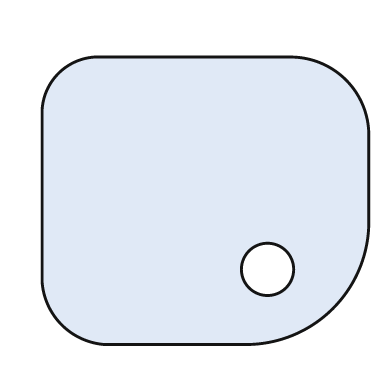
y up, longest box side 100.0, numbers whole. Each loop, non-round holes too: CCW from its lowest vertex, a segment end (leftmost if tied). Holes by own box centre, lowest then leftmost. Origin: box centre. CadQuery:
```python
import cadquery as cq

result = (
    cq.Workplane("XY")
    .moveTo(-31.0, -44.0)
    .lineTo(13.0, -44.0)
    .threePointArc((39.0, -33.0), (50.0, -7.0))
    .lineTo(50.0, 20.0)
    .threePointArc((43.0, 37.0), (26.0, 44.0))
    .lineTo(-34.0, 44.0)
    .threePointArc((-45.0, 39.0), (-50.0, 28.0))
    .lineTo(-50.0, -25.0)
    .threePointArc((-44.0, -38.0), (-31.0, -44.0))
    .close()
    .moveTo(19.0, -21.0)
    .circle(8.0)
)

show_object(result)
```